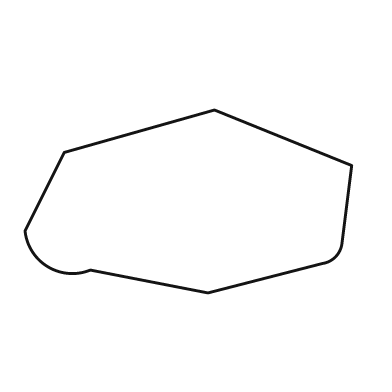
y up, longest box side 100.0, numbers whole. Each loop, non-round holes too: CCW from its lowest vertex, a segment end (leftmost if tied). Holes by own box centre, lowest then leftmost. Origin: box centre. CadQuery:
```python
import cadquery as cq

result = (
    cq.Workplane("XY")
    .moveTo(6.0, -28.0)
    .lineTo(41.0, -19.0)
    .threePointArc((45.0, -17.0), (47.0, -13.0))
    .lineTo(50.0, 11.0)
    .lineTo(8.0, 28.0)
    .lineTo(-38.0, 15.0)
    .lineTo(-50.0, -9.0)
    .threePointArc((-43.0, -20.0), (-30.0, -21.0))
    .close()
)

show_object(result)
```